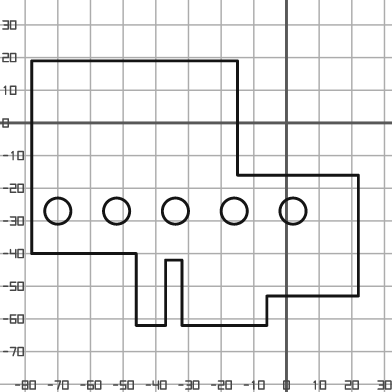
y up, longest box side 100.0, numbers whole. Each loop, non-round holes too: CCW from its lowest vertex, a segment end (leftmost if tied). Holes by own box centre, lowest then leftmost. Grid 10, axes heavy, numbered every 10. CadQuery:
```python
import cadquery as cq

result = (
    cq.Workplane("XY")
    .moveTo(-46.0, -62.0)
    .lineTo(-37.0, -62.0)
    .lineTo(-37.0, -42.0)
    .lineTo(-32.0, -42.0)
    .lineTo(-32.0, -62.0)
    .lineTo(-6.0, -62.0)
    .lineTo(-6.0, -53.0)
    .lineTo(22.0, -53.0)
    .lineTo(22.0, -16.0)
    .lineTo(-15.0, -16.0)
    .lineTo(-15.0, 19.0)
    .lineTo(-78.0, 19.0)
    .lineTo(-78.0, -40.0)
    .lineTo(-46.0, -40.0)
    .close()
    .moveTo(-70.0, -27.0)
    .circle(4.0)
    .moveTo(-52.0, -27.0)
    .circle(4.0)
    .moveTo(-34.0, -27.0)
    .circle(4.0)
    .moveTo(-16.0, -27.0)
    .circle(4.0)
    .moveTo(2.0, -27.0)
    .circle(4.0)
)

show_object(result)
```